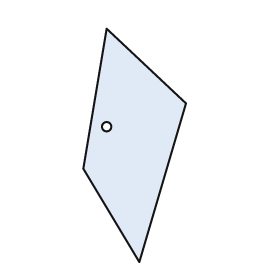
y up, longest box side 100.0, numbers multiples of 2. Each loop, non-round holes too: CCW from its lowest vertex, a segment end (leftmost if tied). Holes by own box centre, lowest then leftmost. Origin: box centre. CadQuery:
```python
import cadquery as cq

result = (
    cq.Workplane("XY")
    .moveTo(2.0, -50.0)
    .lineTo(22.0, 18.0)
    .lineTo(-12.0, 50.0)
    .lineTo(-22.0, -10.0)
    .close()
    .moveTo(-12.0, 8.0)
    .circle(2.0)
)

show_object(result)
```